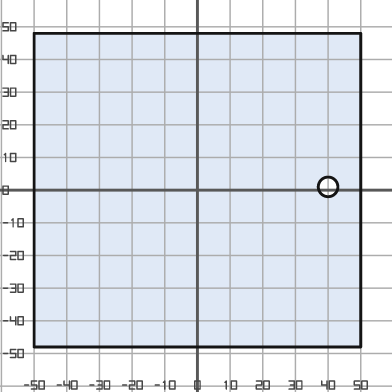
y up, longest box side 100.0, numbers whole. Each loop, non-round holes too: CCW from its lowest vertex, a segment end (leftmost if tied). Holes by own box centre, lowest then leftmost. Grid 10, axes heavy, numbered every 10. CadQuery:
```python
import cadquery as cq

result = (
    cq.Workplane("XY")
    .moveTo(-50.0, -48.0)
    .lineTo(50.0, -48.0)
    .lineTo(50.0, 48.0)
    .lineTo(-50.0, 48.0)
    .close()
    .moveTo(40.0, 1.0)
    .circle(3.0)
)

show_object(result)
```